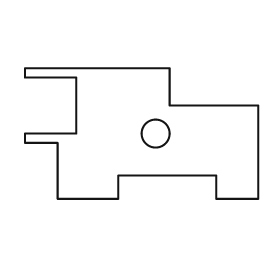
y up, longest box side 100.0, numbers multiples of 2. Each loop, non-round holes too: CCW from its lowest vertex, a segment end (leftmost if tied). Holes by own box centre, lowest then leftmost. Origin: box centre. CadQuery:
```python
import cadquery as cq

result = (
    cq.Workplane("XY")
    .moveTo(-36.0, -28.0)
    .lineTo(-10.0, -28.0)
    .lineTo(-10.0, -18.0)
    .lineTo(32.0, -18.0)
    .lineTo(32.0, -28.0)
    .lineTo(50.0, -28.0)
    .lineTo(50.0, 12.0)
    .lineTo(12.0, 12.0)
    .lineTo(12.0, 28.0)
    .lineTo(-50.0, 28.0)
    .lineTo(-50.0, 24.0)
    .lineTo(-28.0, 24.0)
    .lineTo(-28.0, 0.0)
    .lineTo(-50.0, 0.0)
    .lineTo(-50.0, -4.0)
    .lineTo(-36.0, -4.0)
    .close()
    .moveTo(6.0, 0.0)
    .circle(6.0)
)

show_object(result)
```